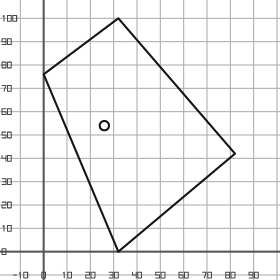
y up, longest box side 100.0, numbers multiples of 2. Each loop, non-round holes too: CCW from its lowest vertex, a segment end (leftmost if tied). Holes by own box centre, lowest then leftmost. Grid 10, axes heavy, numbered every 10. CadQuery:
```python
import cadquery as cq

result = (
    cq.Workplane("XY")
    .moveTo(32.0, 0.0)
    .lineTo(82.0, 42.0)
    .lineTo(32.0, 100.0)
    .lineTo(0.0, 76.0)
    .close()
    .moveTo(26.0, 54.0)
    .circle(2.0)
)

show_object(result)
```